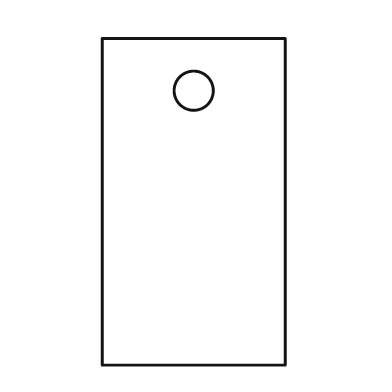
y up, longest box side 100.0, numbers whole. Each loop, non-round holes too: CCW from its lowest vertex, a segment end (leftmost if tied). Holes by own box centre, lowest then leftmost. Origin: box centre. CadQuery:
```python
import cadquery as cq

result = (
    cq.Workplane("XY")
    .moveTo(-28.0, -50.0)
    .lineTo(28.0, -50.0)
    .lineTo(28.0, 50.0)
    .lineTo(-28.0, 50.0)
    .close()
    .moveTo(0.0, 34.0)
    .circle(6.0)
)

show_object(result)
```